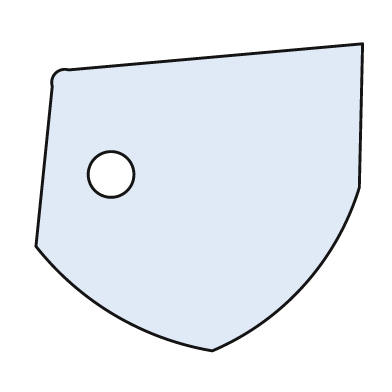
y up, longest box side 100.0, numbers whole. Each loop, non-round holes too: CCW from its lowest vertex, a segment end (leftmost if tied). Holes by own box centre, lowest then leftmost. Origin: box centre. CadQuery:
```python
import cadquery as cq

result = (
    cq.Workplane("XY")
    .moveTo(4.0, -47.0)
    .threePointArc((32.0, -27.0), (49.0, 3.0))
    .lineTo(50.0, 47.0)
    .lineTo(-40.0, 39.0)
    .threePointArc((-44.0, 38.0), (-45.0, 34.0))
    .lineTo(-50.0, -15.0)
    .threePointArc((-26.0, -36.0), (4.0, -47.0))
    .close()
    .moveTo(-27.0, 7.0)
    .circle(7.0)
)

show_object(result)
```